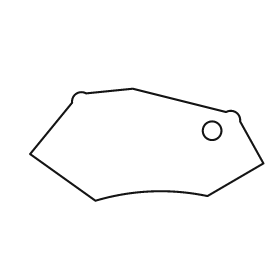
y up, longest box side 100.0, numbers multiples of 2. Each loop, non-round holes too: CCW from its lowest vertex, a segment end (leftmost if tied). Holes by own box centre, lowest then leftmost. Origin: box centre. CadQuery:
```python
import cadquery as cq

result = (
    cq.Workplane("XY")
    .moveTo(-22.0, -24.0)
    .threePointArc((2.0, -20.0), (26.0, -22.0))
    .lineTo(50.0, -8.0)
    .lineTo(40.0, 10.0)
    .threePointArc((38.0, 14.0), (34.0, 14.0))
    .lineTo(-6.0, 24.0)
    .lineTo(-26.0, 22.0)
    .threePointArc((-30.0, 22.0), (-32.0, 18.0))
    .lineTo(-50.0, -4.0)
    .close()
    .moveTo(28.0, 6.0)
    .circle(4.0)
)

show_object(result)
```